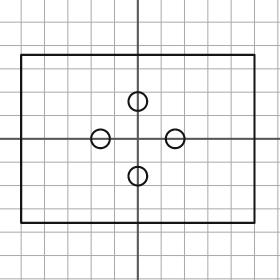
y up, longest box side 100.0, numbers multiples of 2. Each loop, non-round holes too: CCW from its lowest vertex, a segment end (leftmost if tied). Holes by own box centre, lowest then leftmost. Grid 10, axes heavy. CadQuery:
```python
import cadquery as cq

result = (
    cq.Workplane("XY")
    .moveTo(-50.0, -36.0)
    .lineTo(50.0, -36.0)
    .lineTo(50.0, 36.0)
    .lineTo(-50.0, 36.0)
    .close()
    .moveTo(0.0, -16.0)
    .circle(4.0)
    .moveTo(-16.0, 0.0)
    .circle(4.0)
    .moveTo(16.0, 0.0)
    .circle(4.0)
    .moveTo(0.0, 16.0)
    .circle(4.0)
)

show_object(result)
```